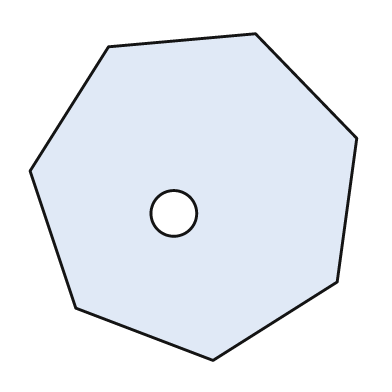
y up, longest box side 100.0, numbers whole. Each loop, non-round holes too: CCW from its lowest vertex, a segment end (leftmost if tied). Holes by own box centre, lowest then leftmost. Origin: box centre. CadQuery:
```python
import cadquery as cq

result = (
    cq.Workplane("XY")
    .moveTo(6.0, -50.0)
    .lineTo(44.0, -26.0)
    .lineTo(50.0, 18.0)
    .lineTo(19.0, 50.0)
    .lineTo(-26.0, 46.0)
    .lineTo(-50.0, 8.0)
    .lineTo(-36.0, -34.0)
    .close()
    .moveTo(-6.0, -5.0)
    .circle(7.0)
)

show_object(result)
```